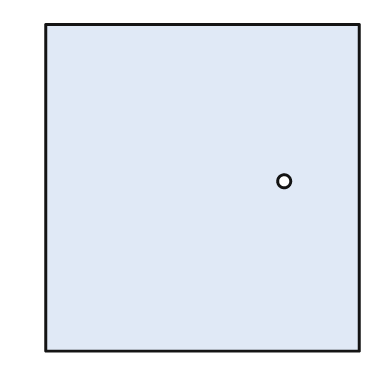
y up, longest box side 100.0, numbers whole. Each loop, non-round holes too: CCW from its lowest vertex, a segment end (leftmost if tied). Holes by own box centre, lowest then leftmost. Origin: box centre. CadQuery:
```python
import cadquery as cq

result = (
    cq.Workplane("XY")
    .moveTo(-48.0, -50.0)
    .lineTo(48.0, -50.0)
    .lineTo(48.0, 50.0)
    .lineTo(-48.0, 50.0)
    .close()
    .moveTo(25.0, 2.0)
    .circle(2.0)
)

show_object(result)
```